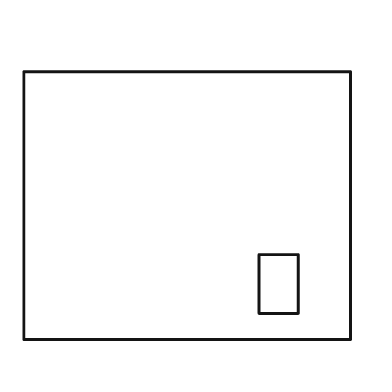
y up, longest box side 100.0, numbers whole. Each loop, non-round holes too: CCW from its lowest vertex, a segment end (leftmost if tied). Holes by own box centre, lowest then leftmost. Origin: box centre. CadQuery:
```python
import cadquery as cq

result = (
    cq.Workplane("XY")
    .moveTo(-50.0, -41.0)
    .lineTo(50.0, -41.0)
    .lineTo(50.0, 41.0)
    .lineTo(-50.0, 41.0)
    .close()
    .moveTo(22.0, -33.0)
    .lineTo(34.0, -33.0)
    .lineTo(34.0, -15.0)
    .lineTo(22.0, -15.0)
    .close()
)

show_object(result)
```